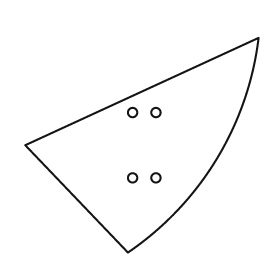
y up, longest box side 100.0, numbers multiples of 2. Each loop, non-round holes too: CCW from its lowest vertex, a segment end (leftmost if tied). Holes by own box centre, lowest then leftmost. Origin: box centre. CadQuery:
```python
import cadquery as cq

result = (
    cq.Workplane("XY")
    .moveTo(-6.0, -46.0)
    .threePointArc((32.0, -6.0), (50.0, 46.0))
    .lineTo(-50.0, 0.0)
    .close()
    .moveTo(-4.0, -14.0)
    .circle(2.0)
    .moveTo(6.0, -14.0)
    .circle(2.0)
    .moveTo(-4.0, 14.0)
    .circle(2.0)
    .moveTo(6.0, 14.0)
    .circle(2.0)
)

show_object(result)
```